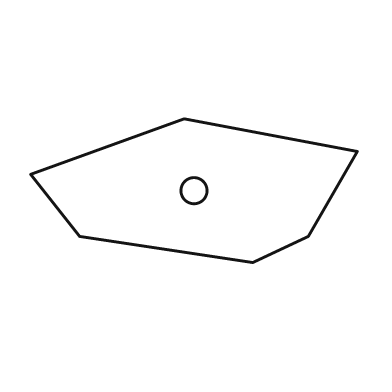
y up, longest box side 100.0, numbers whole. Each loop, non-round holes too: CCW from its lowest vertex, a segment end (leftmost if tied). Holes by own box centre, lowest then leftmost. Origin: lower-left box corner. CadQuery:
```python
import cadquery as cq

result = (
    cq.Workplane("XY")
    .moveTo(68.0, 0.0)
    .lineTo(85.0, 8.0)
    .lineTo(100.0, 34.0)
    .lineTo(47.0, 44.0)
    .lineTo(0.0, 27.0)
    .lineTo(15.0, 8.0)
    .close()
    .moveTo(50.0, 22.0)
    .circle(4.0)
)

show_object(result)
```